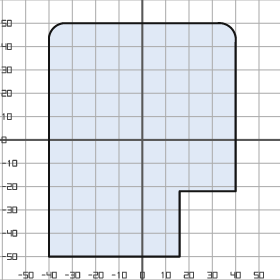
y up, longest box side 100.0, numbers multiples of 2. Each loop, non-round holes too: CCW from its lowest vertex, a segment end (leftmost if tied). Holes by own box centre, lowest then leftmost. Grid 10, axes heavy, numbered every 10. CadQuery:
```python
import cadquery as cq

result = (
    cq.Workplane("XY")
    .moveTo(-40.0, -50.0)
    .lineTo(16.0, -50.0)
    .lineTo(16.0, -22.0)
    .lineTo(40.0, -22.0)
    .lineTo(40.0, 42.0)
    .threePointArc((38.0, 48.0), (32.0, 50.0))
    .lineTo(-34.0, 50.0)
    .threePointArc((-38.0, 48.0), (-40.0, 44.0))
    .close()
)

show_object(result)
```